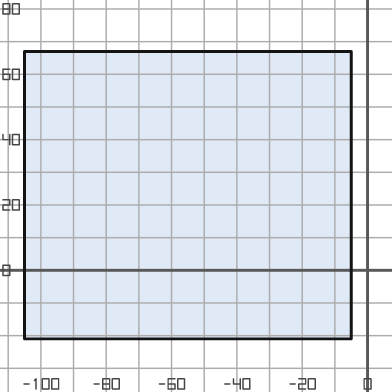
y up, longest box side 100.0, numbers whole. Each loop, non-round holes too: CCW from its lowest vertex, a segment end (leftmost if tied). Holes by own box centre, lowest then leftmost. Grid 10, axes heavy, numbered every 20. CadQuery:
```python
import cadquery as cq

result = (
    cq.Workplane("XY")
    .moveTo(-105.0, -21.0)
    .lineTo(-5.0, -21.0)
    .lineTo(-5.0, 67.0)
    .lineTo(-105.0, 67.0)
    .close()
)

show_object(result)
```